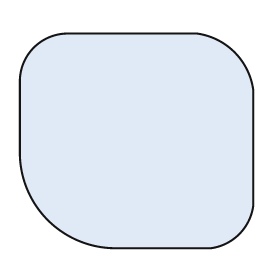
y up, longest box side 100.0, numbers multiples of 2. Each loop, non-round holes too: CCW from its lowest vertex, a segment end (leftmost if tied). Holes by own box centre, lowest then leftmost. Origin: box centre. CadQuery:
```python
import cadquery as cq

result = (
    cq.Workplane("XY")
    .moveTo(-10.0, -46.0)
    .lineTo(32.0, -46.0)
    .threePointArc((44.0, -40.0), (50.0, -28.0))
    .lineTo(50.0, 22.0)
    .threePointArc((42.0, 38.0), (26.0, 46.0))
    .lineTo(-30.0, 46.0)
    .threePointArc((-44.0, 40.0), (-50.0, 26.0))
    .lineTo(-50.0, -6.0)
    .threePointArc((-38.0, -34.0), (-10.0, -46.0))
    .close()
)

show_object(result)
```